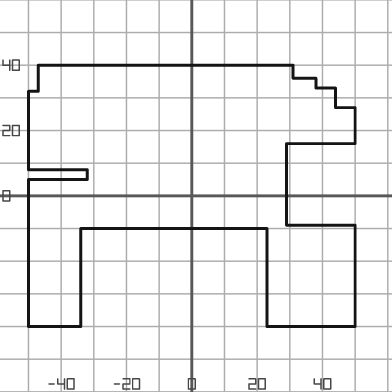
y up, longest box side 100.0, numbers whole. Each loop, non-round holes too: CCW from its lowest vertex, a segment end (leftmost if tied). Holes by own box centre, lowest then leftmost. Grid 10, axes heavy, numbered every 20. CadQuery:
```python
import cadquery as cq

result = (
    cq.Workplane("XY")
    .moveTo(-50.0, -40.0)
    .lineTo(-34.0, -40.0)
    .lineTo(-34.0, -10.0)
    .lineTo(23.0, -10.0)
    .lineTo(23.0, -40.0)
    .lineTo(50.0, -40.0)
    .lineTo(50.0, -9.0)
    .lineTo(29.0, -9.0)
    .lineTo(29.0, 16.0)
    .lineTo(50.0, 16.0)
    .lineTo(50.0, 27.0)
    .lineTo(44.0, 27.0)
    .lineTo(44.0, 33.0)
    .lineTo(38.0, 33.0)
    .lineTo(38.0, 36.0)
    .lineTo(31.0, 36.0)
    .lineTo(31.0, 40.0)
    .lineTo(-47.0, 40.0)
    .lineTo(-47.0, 32.0)
    .lineTo(-50.0, 32.0)
    .lineTo(-50.0, 8.0)
    .lineTo(-32.0, 8.0)
    .lineTo(-32.0, 5.0)
    .lineTo(-50.0, 5.0)
    .close()
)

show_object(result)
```